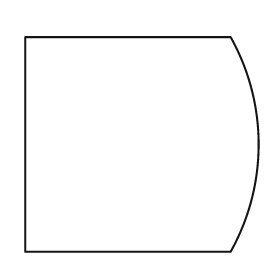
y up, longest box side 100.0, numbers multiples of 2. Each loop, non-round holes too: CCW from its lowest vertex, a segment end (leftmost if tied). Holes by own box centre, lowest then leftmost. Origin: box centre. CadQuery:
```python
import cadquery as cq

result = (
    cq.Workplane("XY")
    .moveTo(-50.0, -46.0)
    .lineTo(38.0, -46.0)
    .threePointArc((50.0, 0.0), (38.0, 46.0))
    .lineTo(-50.0, 46.0)
    .close()
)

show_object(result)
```